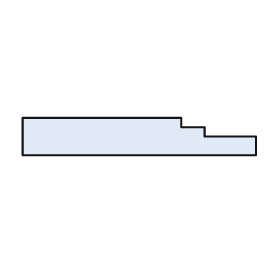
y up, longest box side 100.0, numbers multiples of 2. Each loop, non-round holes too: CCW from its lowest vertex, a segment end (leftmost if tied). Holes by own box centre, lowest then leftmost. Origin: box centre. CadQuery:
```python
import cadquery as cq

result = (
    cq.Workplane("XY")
    .moveTo(-50.0, -8.0)
    .lineTo(50.0, -8.0)
    .lineTo(50.0, 0.0)
    .lineTo(28.0, 0.0)
    .lineTo(28.0, 4.0)
    .lineTo(18.0, 4.0)
    .lineTo(18.0, 8.0)
    .lineTo(-50.0, 8.0)
    .close()
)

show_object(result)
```